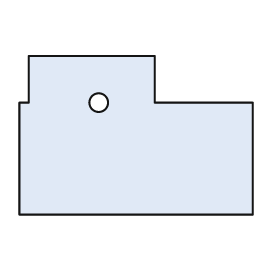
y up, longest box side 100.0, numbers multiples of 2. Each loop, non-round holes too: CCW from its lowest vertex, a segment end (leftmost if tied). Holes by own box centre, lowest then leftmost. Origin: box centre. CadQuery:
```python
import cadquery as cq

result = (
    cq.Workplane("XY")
    .moveTo(-50.0, -34.0)
    .lineTo(50.0, -34.0)
    .lineTo(50.0, 14.0)
    .lineTo(8.0, 14.0)
    .lineTo(8.0, 34.0)
    .lineTo(-46.0, 34.0)
    .lineTo(-46.0, 14.0)
    .lineTo(-50.0, 14.0)
    .close()
    .moveTo(-16.0, 14.0)
    .circle(4.0)
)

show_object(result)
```